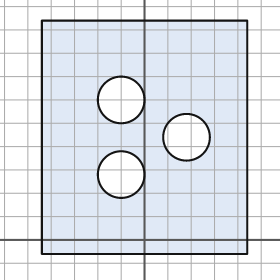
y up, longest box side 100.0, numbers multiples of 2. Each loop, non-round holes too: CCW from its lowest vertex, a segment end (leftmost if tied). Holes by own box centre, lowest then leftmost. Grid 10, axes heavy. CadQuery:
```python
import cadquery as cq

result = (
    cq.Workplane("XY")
    .moveTo(-44.0, -6.0)
    .lineTo(44.0, -6.0)
    .lineTo(44.0, 94.0)
    .lineTo(-44.0, 94.0)
    .close()
    .moveTo(-10.0, 28.0)
    .circle(10.0)
    .moveTo(18.0, 44.0)
    .circle(10.0)
    .moveTo(-10.0, 60.0)
    .circle(10.0)
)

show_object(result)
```